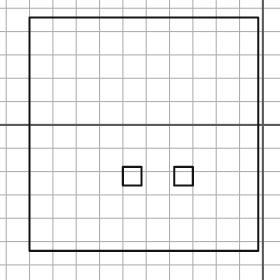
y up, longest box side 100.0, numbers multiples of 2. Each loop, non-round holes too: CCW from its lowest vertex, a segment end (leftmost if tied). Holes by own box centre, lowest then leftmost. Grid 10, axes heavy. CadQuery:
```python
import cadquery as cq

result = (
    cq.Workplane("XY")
    .moveTo(-100.0, -54.0)
    .lineTo(-2.0, -54.0)
    .lineTo(-2.0, 46.0)
    .lineTo(-100.0, 46.0)
    .close()
    .moveTo(-60.0, -26.0)
    .lineTo(-52.0, -26.0)
    .lineTo(-52.0, -18.0)
    .lineTo(-60.0, -18.0)
    .close()
    .moveTo(-38.0, -26.0)
    .lineTo(-30.0, -26.0)
    .lineTo(-30.0, -18.0)
    .lineTo(-38.0, -18.0)
    .close()
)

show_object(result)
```